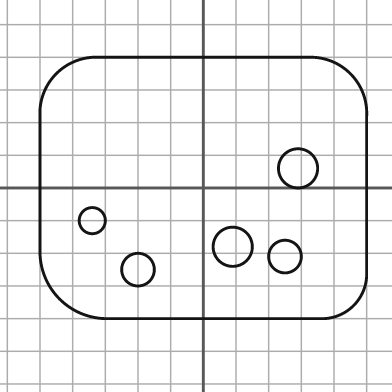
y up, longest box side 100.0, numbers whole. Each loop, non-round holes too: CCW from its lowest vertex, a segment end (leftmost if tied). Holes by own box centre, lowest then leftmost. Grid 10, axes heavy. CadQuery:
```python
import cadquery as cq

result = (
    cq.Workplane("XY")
    .moveTo(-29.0, -40.0)
    .lineTo(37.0, -40.0)
    .threePointArc((46.0, -36.0), (50.0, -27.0))
    .lineTo(50.0, 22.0)
    .threePointArc((45.0, 35.0), (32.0, 40.0))
    .lineTo(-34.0, 40.0)
    .threePointArc((-45.0, 35.0), (-50.0, 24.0))
    .lineTo(-50.0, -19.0)
    .threePointArc((-44.0, -34.0), (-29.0, -40.0))
    .close()
    .moveTo(-20.0, -25.0)
    .circle(5.0)
    .moveTo(25.0, -21.0)
    .circle(5.0)
    .moveTo(9.0, -18.0)
    .circle(6.0)
    .moveTo(-34.0, -10.0)
    .circle(4.0)
    .moveTo(29.0, 6.0)
    .circle(6.0)
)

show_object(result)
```